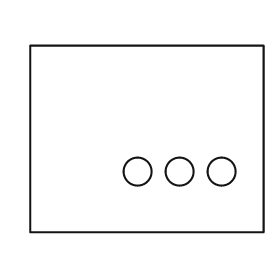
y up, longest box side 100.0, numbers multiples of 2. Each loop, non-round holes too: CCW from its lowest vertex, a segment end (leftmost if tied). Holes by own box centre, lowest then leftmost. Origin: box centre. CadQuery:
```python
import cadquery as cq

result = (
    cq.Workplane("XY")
    .moveTo(-50.0, -40.0)
    .lineTo(50.0, -40.0)
    .lineTo(50.0, 40.0)
    .lineTo(-50.0, 40.0)
    .close()
    .moveTo(-4.0, -14.0)
    .circle(6.0)
    .moveTo(14.0, -14.0)
    .circle(6.0)
    .moveTo(32.0, -14.0)
    .circle(6.0)
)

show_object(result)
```